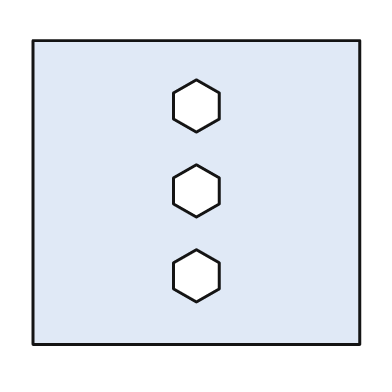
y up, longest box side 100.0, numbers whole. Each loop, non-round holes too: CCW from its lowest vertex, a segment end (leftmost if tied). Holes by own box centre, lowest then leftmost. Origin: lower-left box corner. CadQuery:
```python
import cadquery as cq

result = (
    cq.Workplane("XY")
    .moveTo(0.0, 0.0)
    .lineTo(100.0, 0.0)
    .lineTo(100.0, 93.0)
    .lineTo(0.0, 93.0)
    .close()
    .moveTo(50.0, 13.0)
    .lineTo(57.0, 17.0)
    .lineTo(57.0, 25.0)
    .lineTo(50.0, 29.0)
    .lineTo(43.0, 25.0)
    .lineTo(43.0, 17.0)
    .close()
    .moveTo(50.0, 39.0)
    .lineTo(57.0, 43.0)
    .lineTo(57.0, 51.0)
    .lineTo(50.0, 55.0)
    .lineTo(43.0, 51.0)
    .lineTo(43.0, 43.0)
    .close()
    .moveTo(50.0, 65.0)
    .lineTo(57.0, 69.0)
    .lineTo(57.0, 77.0)
    .lineTo(50.0, 81.0)
    .lineTo(43.0, 77.0)
    .lineTo(43.0, 69.0)
    .close()
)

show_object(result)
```